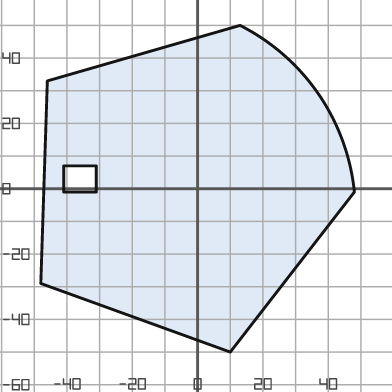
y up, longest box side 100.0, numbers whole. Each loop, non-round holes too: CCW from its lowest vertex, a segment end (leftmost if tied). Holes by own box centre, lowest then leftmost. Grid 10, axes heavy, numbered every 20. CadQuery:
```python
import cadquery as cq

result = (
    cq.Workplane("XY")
    .moveTo(10.0, -50.0)
    .lineTo(48.0, -1.0)
    .threePointArc((37.0, 29.0), (13.0, 50.0))
    .lineTo(-46.0, 33.0)
    .lineTo(-48.0, -29.0)
    .close()
    .moveTo(-41.0, -1.0)
    .lineTo(-31.0, -1.0)
    .lineTo(-31.0, 7.0)
    .lineTo(-41.0, 7.0)
    .close()
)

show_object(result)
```